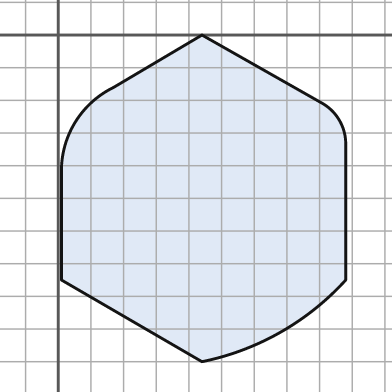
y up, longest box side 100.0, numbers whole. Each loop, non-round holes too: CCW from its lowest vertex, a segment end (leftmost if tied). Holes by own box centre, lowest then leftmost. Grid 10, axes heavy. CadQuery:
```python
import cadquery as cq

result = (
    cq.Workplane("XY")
    .moveTo(44.0, -100.0)
    .threePointArc((68.0, -91.0), (88.0, -75.0))
    .lineTo(88.0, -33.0)
    .threePointArc((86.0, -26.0), (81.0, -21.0))
    .lineTo(44.0, 0.0)
    .lineTo(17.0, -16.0)
    .threePointArc((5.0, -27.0), (1.0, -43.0))
    .lineTo(1.0, -75.0)
    .close()
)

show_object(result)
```